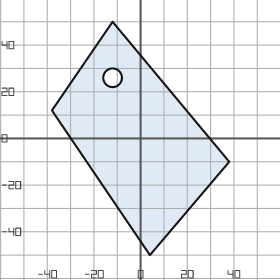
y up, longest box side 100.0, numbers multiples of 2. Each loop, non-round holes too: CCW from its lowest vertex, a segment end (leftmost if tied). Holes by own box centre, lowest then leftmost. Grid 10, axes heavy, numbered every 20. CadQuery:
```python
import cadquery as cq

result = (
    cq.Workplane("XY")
    .moveTo(4.0, -50.0)
    .lineTo(38.0, -10.0)
    .lineTo(-12.0, 50.0)
    .lineTo(-38.0, 12.0)
    .close()
    .moveTo(-12.0, 26.0)
    .circle(4.0)
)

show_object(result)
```